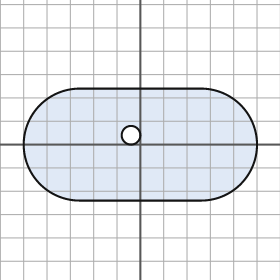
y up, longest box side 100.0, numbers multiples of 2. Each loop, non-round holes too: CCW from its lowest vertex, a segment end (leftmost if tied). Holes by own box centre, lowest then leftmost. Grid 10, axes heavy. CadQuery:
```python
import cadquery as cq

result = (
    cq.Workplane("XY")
    .moveTo(-26.0, -24.0)
    .lineTo(26.0, -24.0)
    .threePointArc((50.0, 0.0), (26.0, 24.0))
    .lineTo(-26.0, 24.0)
    .threePointArc((-50.0, 0.0), (-26.0, -24.0))
    .close()
    .moveTo(-4.0, 4.0)
    .circle(4.0)
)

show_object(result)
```